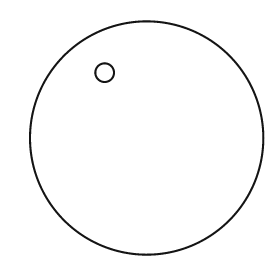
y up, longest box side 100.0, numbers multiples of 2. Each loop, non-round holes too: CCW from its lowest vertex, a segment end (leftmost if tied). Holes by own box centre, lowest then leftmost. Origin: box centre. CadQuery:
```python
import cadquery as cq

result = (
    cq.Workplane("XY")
    .moveTo(0.0, 0.0)
    .circle(50.0)
    .moveTo(-18.0, 28.0)
    .circle(4.0)
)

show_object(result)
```